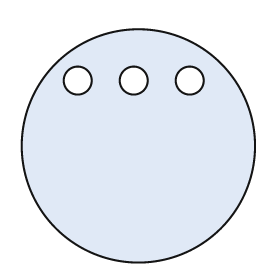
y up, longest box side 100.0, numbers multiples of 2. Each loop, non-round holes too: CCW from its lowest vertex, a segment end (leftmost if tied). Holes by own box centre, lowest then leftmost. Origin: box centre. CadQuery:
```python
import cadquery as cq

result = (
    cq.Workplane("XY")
    .moveTo(0.0, 0.0)
    .circle(50.0)
    .moveTo(-26.0, 28.0)
    .circle(6.0)
    .moveTo(-2.0, 28.0)
    .circle(6.0)
    .moveTo(22.0, 28.0)
    .circle(6.0)
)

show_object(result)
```